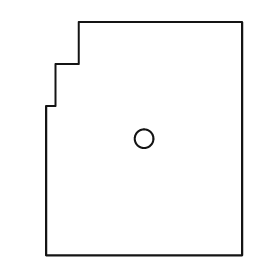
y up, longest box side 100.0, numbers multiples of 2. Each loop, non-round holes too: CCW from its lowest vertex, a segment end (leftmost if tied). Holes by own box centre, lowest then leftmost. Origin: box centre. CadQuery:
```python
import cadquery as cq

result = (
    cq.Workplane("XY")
    .moveTo(-42.0, -50.0)
    .lineTo(42.0, -50.0)
    .lineTo(42.0, 50.0)
    .lineTo(-28.0, 50.0)
    .lineTo(-28.0, 32.0)
    .lineTo(-38.0, 32.0)
    .lineTo(-38.0, 14.0)
    .lineTo(-42.0, 14.0)
    .close()
    .moveTo(0.0, 0.0)
    .circle(4.0)
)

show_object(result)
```